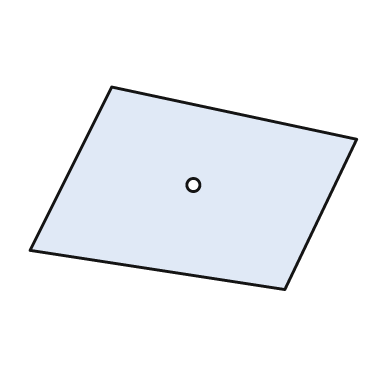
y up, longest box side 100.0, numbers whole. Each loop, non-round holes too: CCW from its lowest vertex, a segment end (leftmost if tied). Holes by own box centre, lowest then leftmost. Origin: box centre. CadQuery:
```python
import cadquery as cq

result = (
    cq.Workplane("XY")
    .moveTo(28.0, -31.0)
    .lineTo(50.0, 15.0)
    .lineTo(-25.0, 31.0)
    .lineTo(-50.0, -19.0)
    .close()
    .moveTo(0.0, 1.0)
    .circle(2.0)
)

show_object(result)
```